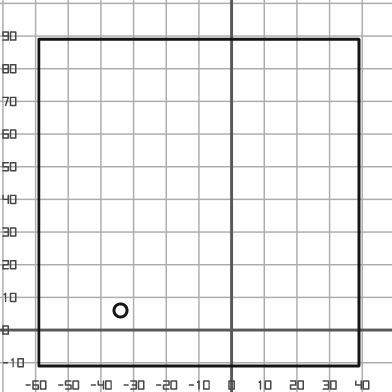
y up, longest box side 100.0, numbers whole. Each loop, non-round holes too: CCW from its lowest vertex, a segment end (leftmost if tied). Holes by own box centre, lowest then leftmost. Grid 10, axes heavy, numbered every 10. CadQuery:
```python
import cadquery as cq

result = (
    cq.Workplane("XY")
    .moveTo(-59.0, -11.0)
    .lineTo(39.0, -11.0)
    .lineTo(39.0, 89.0)
    .lineTo(-59.0, 89.0)
    .close()
    .moveTo(-34.0, 6.0)
    .circle(2.0)
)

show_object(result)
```